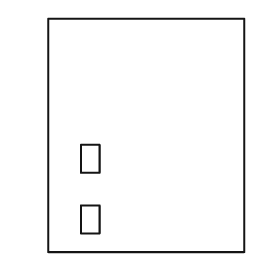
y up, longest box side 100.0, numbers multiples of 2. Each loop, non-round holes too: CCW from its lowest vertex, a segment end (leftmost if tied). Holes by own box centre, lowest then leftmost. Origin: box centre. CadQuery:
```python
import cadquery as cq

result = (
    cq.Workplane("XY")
    .moveTo(-42.0, -50.0)
    .lineTo(42.0, -50.0)
    .lineTo(42.0, 50.0)
    .lineTo(-42.0, 50.0)
    .close()
    .moveTo(-28.0, -42.0)
    .lineTo(-20.0, -42.0)
    .lineTo(-20.0, -30.0)
    .lineTo(-28.0, -30.0)
    .close()
    .moveTo(-28.0, -16.0)
    .lineTo(-20.0, -16.0)
    .lineTo(-20.0, -4.0)
    .lineTo(-28.0, -4.0)
    .close()
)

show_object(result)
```